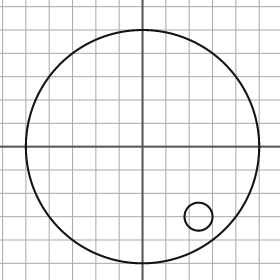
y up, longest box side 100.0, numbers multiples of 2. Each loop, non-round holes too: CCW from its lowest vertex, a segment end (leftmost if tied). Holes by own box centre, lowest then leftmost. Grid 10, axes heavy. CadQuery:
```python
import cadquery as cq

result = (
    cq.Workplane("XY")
    .moveTo(0.0, 0.0)
    .circle(50.0)
    .moveTo(24.0, -30.0)
    .circle(6.0)
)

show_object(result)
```